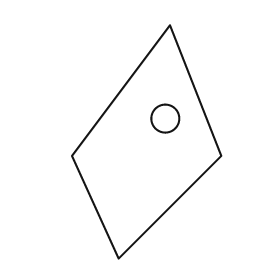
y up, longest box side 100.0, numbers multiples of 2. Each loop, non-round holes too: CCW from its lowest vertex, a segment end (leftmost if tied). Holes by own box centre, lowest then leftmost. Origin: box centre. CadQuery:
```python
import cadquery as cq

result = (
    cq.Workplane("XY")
    .moveTo(-12.0, -50.0)
    .lineTo(32.0, -6.0)
    .lineTo(10.0, 50.0)
    .lineTo(-32.0, -6.0)
    .close()
    .moveTo(8.0, 10.0)
    .circle(6.0)
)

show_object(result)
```